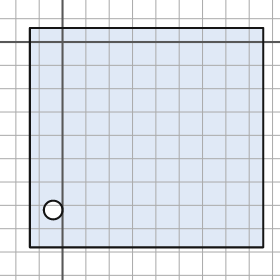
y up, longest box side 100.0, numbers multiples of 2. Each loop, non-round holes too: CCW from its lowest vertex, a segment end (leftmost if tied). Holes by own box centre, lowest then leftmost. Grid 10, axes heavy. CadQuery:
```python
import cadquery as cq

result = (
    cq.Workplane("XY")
    .moveTo(-14.0, -88.0)
    .lineTo(86.0, -88.0)
    .lineTo(86.0, 6.0)
    .lineTo(-14.0, 6.0)
    .close()
    .moveTo(-4.0, -72.0)
    .circle(4.0)
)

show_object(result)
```